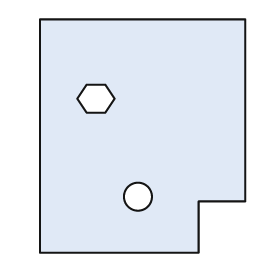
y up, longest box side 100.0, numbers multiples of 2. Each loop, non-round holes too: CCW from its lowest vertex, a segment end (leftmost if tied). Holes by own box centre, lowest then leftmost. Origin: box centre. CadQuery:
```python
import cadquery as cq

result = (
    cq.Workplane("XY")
    .moveTo(-44.0, -50.0)
    .lineTo(24.0, -50.0)
    .lineTo(24.0, -28.0)
    .lineTo(44.0, -28.0)
    .lineTo(44.0, 50.0)
    .lineTo(-44.0, 50.0)
    .close()
    .moveTo(-2.0, -26.0)
    .circle(6.0)
    .moveTo(-24.0, 10.0)
    .lineTo(-16.0, 10.0)
    .lineTo(-12.0, 16.0)
    .lineTo(-16.0, 22.0)
    .lineTo(-24.0, 22.0)
    .lineTo(-28.0, 16.0)
    .close()
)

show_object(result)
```